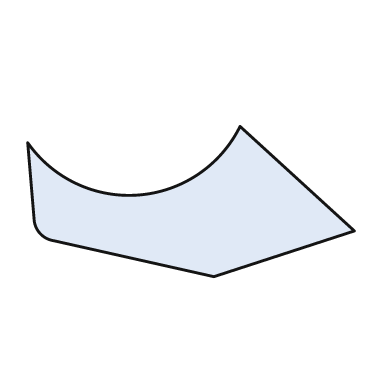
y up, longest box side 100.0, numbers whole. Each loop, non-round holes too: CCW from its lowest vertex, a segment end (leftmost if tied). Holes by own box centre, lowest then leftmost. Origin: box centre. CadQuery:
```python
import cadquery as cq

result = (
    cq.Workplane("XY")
    .moveTo(7.0, -23.0)
    .lineTo(50.0, -9.0)
    .lineTo(15.0, 23.0)
    .threePointArc((-16.0, 2.0), (-50.0, 18.0))
    .lineTo(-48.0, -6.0)
    .threePointArc((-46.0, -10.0), (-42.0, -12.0))
    .close()
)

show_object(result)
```